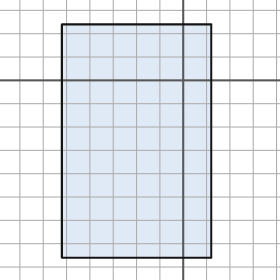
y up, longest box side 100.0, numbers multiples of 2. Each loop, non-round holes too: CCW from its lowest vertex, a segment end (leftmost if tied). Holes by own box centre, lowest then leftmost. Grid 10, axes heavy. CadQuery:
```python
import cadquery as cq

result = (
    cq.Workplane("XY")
    .moveTo(-52.0, -76.0)
    .lineTo(12.0, -76.0)
    .lineTo(12.0, 24.0)
    .lineTo(-52.0, 24.0)
    .close()
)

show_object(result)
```